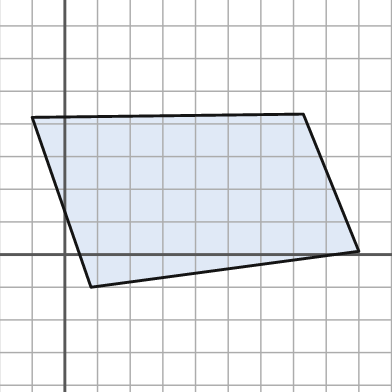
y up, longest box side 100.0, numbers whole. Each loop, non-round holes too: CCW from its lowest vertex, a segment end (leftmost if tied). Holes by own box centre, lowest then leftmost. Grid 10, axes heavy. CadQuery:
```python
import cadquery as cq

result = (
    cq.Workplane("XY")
    .moveTo(8.0, -10.0)
    .lineTo(90.0, 1.0)
    .lineTo(73.0, 43.0)
    .lineTo(-10.0, 42.0)
    .close()
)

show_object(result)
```